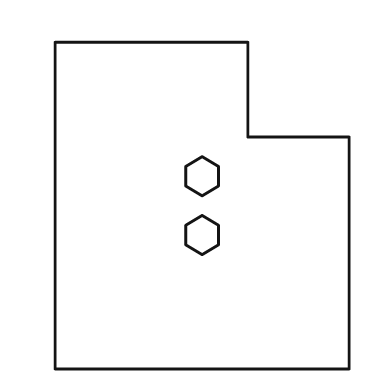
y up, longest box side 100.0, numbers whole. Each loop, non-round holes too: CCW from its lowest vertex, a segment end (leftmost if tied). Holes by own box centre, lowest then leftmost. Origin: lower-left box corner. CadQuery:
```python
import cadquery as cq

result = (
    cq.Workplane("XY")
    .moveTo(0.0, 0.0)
    .lineTo(90.0, 0.0)
    .lineTo(90.0, 71.0)
    .lineTo(59.0, 71.0)
    .lineTo(59.0, 100.0)
    .lineTo(0.0, 100.0)
    .close()
    .moveTo(45.0, 35.0)
    .lineTo(50.0, 38.0)
    .lineTo(50.0, 44.0)
    .lineTo(45.0, 47.0)
    .lineTo(40.0, 44.0)
    .lineTo(40.0, 38.0)
    .close()
    .moveTo(45.0, 53.0)
    .lineTo(50.0, 56.0)
    .lineTo(50.0, 62.0)
    .lineTo(45.0, 65.0)
    .lineTo(40.0, 62.0)
    .lineTo(40.0, 56.0)
    .close()
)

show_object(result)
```